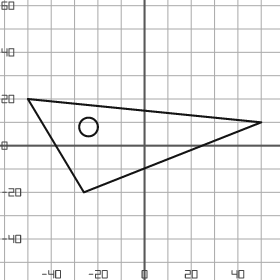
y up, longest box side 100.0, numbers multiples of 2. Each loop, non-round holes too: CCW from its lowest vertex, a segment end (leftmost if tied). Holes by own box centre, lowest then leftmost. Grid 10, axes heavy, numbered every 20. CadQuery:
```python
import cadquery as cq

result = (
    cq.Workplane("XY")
    .moveTo(-26.0, -20.0)
    .lineTo(50.0, 10.0)
    .lineTo(-50.0, 20.0)
    .close()
    .moveTo(-24.0, 8.0)
    .circle(4.0)
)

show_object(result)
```